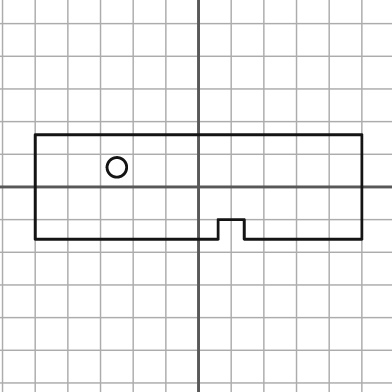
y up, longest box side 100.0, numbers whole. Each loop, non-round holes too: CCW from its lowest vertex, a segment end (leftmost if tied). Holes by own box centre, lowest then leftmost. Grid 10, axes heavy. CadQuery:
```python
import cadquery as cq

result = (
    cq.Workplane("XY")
    .moveTo(-50.0, -16.0)
    .lineTo(6.0, -16.0)
    .lineTo(6.0, -10.0)
    .lineTo(14.0, -10.0)
    .lineTo(14.0, -16.0)
    .lineTo(50.0, -16.0)
    .lineTo(50.0, 16.0)
    .lineTo(-50.0, 16.0)
    .close()
    .moveTo(-25.0, 6.0)
    .circle(3.0)
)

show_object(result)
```